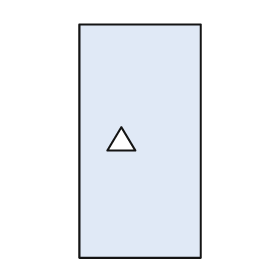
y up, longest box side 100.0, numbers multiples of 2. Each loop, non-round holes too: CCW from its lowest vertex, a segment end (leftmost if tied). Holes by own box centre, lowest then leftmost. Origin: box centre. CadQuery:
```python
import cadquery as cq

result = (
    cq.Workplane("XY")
    .moveTo(-26.0, -50.0)
    .lineTo(26.0, -50.0)
    .lineTo(26.0, 50.0)
    .lineTo(-26.0, 50.0)
    .close()
    .moveTo(-14.0, -4.0)
    .lineTo(-2.0, -4.0)
    .lineTo(-8.0, 6.0)
    .close()
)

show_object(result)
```